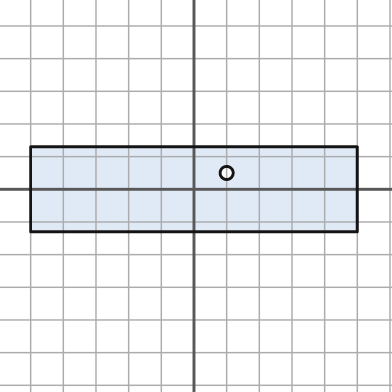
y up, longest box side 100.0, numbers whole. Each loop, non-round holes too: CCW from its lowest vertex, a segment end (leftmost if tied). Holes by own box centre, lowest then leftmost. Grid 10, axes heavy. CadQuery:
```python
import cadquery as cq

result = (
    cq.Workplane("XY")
    .moveTo(-50.0, -13.0)
    .lineTo(50.0, -13.0)
    .lineTo(50.0, 13.0)
    .lineTo(-50.0, 13.0)
    .close()
    .moveTo(10.0, 5.0)
    .circle(2.0)
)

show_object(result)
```